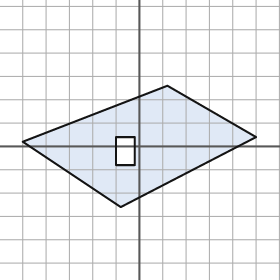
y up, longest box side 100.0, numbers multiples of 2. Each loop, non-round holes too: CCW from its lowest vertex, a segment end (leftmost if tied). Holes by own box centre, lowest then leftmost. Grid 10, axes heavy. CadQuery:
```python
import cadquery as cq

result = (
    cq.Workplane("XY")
    .moveTo(-8.0, -26.0)
    .lineTo(50.0, 4.0)
    .lineTo(12.0, 26.0)
    .lineTo(-50.0, 2.0)
    .close()
    .moveTo(-10.0, -8.0)
    .lineTo(-2.0, -8.0)
    .lineTo(-2.0, 4.0)
    .lineTo(-10.0, 4.0)
    .close()
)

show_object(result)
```